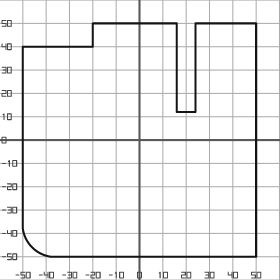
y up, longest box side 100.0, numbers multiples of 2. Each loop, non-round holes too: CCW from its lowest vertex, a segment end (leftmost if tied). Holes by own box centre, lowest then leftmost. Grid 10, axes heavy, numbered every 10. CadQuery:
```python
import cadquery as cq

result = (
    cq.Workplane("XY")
    .moveTo(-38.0, -50.0)
    .lineTo(50.0, -50.0)
    .lineTo(50.0, 50.0)
    .lineTo(24.0, 50.0)
    .lineTo(24.0, 12.0)
    .lineTo(16.0, 12.0)
    .lineTo(16.0, 50.0)
    .lineTo(-20.0, 50.0)
    .lineTo(-20.0, 40.0)
    .lineTo(-50.0, 40.0)
    .lineTo(-50.0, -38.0)
    .threePointArc((-46.0, -46.0), (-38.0, -50.0))
    .close()
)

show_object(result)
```